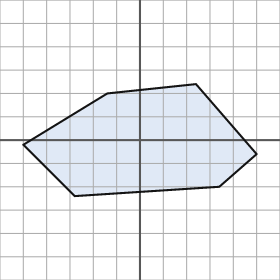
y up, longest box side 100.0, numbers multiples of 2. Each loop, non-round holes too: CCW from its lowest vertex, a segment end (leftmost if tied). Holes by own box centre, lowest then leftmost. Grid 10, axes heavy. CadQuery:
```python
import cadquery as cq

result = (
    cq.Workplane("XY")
    .moveTo(-28.0, -24.0)
    .lineTo(34.0, -20.0)
    .lineTo(50.0, -6.0)
    .lineTo(24.0, 24.0)
    .lineTo(-14.0, 20.0)
    .lineTo(-50.0, -2.0)
    .close()
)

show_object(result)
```